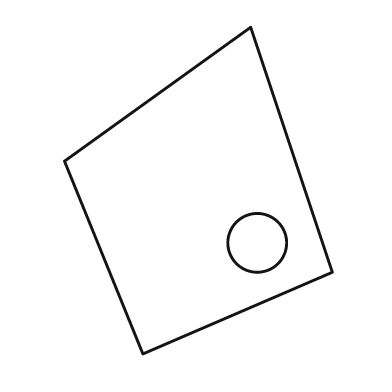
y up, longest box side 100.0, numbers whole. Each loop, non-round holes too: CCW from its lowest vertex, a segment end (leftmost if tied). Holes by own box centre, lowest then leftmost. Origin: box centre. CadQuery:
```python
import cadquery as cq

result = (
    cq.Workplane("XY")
    .moveTo(-17.0, -50.0)
    .lineTo(41.0, -25.0)
    .lineTo(16.0, 50.0)
    .lineTo(-41.0, 9.0)
    .close()
    .moveTo(18.0, -16.0)
    .circle(9.0)
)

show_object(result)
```